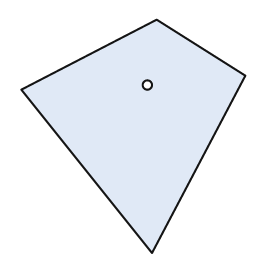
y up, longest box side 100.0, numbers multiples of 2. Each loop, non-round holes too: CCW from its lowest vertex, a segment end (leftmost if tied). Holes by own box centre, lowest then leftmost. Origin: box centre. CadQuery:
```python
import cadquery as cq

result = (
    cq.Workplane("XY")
    .moveTo(8.0, -50.0)
    .lineTo(48.0, 26.0)
    .lineTo(10.0, 50.0)
    .lineTo(-48.0, 20.0)
    .close()
    .moveTo(6.0, 22.0)
    .circle(2.0)
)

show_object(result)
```